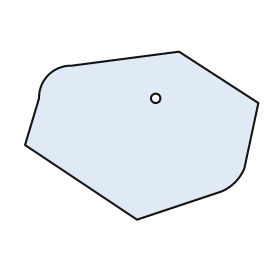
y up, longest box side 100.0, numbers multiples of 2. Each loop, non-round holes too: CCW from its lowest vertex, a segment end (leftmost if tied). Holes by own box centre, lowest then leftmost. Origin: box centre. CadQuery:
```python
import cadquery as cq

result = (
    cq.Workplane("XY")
    .moveTo(-2.0, -36.0)
    .lineTo(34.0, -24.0)
    .threePointArc((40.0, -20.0), (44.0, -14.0))
    .lineTo(50.0, 14.0)
    .lineTo(16.0, 36.0)
    .lineTo(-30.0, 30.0)
    .threePointArc((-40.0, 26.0), (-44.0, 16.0))
    .lineTo(-50.0, -4.0)
    .close()
    .moveTo(6.0, 16.0)
    .circle(2.0)
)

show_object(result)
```